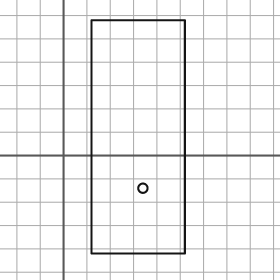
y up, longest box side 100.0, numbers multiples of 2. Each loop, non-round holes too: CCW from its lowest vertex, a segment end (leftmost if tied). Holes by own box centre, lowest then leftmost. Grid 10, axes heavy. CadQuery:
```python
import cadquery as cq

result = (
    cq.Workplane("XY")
    .moveTo(12.0, -42.0)
    .lineTo(52.0, -42.0)
    .lineTo(52.0, 58.0)
    .lineTo(12.0, 58.0)
    .close()
    .moveTo(34.0, -14.0)
    .circle(2.0)
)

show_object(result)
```